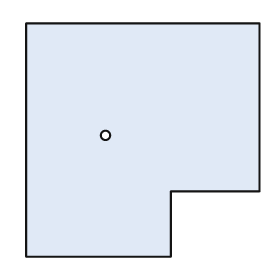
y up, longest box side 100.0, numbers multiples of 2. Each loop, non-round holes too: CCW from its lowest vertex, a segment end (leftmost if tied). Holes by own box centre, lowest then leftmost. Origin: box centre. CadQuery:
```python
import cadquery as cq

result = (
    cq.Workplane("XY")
    .moveTo(-50.0, -50.0)
    .lineTo(12.0, -50.0)
    .lineTo(12.0, -22.0)
    .lineTo(50.0, -22.0)
    .lineTo(50.0, 50.0)
    .lineTo(-50.0, 50.0)
    .close()
    .moveTo(-16.0, 2.0)
    .circle(2.0)
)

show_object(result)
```